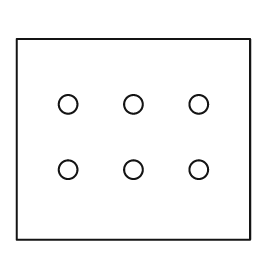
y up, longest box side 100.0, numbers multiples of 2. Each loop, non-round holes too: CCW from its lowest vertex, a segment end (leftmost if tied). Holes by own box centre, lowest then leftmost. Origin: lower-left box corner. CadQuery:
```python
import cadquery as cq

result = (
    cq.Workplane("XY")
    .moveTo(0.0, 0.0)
    .lineTo(100.0, 0.0)
    .lineTo(100.0, 86.0)
    .lineTo(0.0, 86.0)
    .close()
    .moveTo(22.0, 30.0)
    .circle(4.0)
    .moveTo(50.0, 30.0)
    .circle(4.0)
    .moveTo(78.0, 30.0)
    .circle(4.0)
    .moveTo(22.0, 58.0)
    .circle(4.0)
    .moveTo(50.0, 58.0)
    .circle(4.0)
    .moveTo(78.0, 58.0)
    .circle(4.0)
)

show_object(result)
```